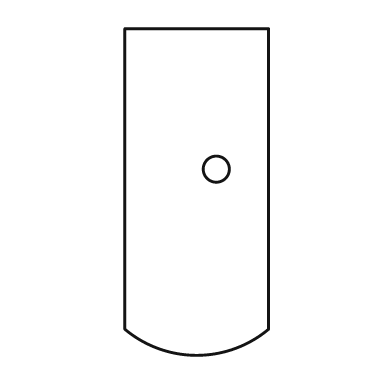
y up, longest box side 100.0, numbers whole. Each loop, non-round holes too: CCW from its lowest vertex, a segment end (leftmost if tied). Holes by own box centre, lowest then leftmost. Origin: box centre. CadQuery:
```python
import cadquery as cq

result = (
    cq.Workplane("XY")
    .moveTo(-22.0, -42.0)
    .threePointArc((0.0, -50.0), (22.0, -42.0))
    .lineTo(22.0, 50.0)
    .lineTo(-22.0, 50.0)
    .close()
    .moveTo(6.0, 7.0)
    .circle(4.0)
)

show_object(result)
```